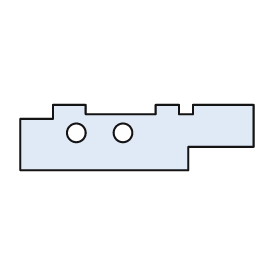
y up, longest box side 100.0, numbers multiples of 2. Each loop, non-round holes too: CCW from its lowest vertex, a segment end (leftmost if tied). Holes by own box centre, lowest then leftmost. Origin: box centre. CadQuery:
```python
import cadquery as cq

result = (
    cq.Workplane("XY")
    .moveTo(-50.0, -14.0)
    .lineTo(22.0, -14.0)
    .lineTo(22.0, -4.0)
    .lineTo(50.0, -4.0)
    .lineTo(50.0, 14.0)
    .lineTo(24.0, 14.0)
    .lineTo(24.0, 10.0)
    .lineTo(18.0, 10.0)
    .lineTo(18.0, 14.0)
    .lineTo(8.0, 14.0)
    .lineTo(8.0, 10.0)
    .lineTo(-22.0, 10.0)
    .lineTo(-22.0, 14.0)
    .lineTo(-36.0, 14.0)
    .lineTo(-36.0, 8.0)
    .lineTo(-50.0, 8.0)
    .close()
    .moveTo(-26.0, 2.0)
    .circle(4.0)
    .moveTo(-6.0, 2.0)
    .circle(4.0)
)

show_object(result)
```